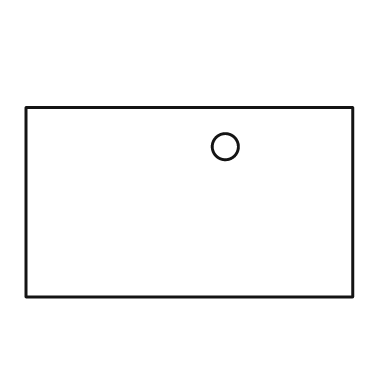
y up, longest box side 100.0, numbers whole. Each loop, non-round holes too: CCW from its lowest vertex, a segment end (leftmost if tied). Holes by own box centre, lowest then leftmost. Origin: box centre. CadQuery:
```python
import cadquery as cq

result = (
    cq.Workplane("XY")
    .moveTo(-50.0, -29.0)
    .lineTo(50.0, -29.0)
    .lineTo(50.0, 29.0)
    .lineTo(-50.0, 29.0)
    .close()
    .moveTo(11.0, 17.0)
    .circle(4.0)
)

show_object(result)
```